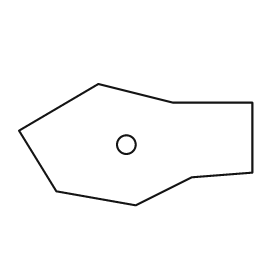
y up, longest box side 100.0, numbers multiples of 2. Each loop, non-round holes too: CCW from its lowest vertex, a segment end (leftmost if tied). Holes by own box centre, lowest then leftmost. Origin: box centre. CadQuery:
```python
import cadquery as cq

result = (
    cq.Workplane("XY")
    .moveTo(0.0, -26.0)
    .lineTo(24.0, -14.0)
    .lineTo(50.0, -12.0)
    .lineTo(50.0, 18.0)
    .lineTo(16.0, 18.0)
    .lineTo(-16.0, 26.0)
    .lineTo(-50.0, 6.0)
    .lineTo(-34.0, -20.0)
    .close()
    .moveTo(-4.0, 0.0)
    .circle(4.0)
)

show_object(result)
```